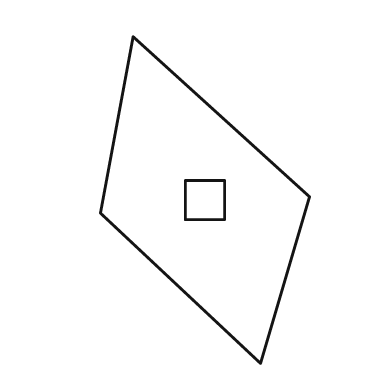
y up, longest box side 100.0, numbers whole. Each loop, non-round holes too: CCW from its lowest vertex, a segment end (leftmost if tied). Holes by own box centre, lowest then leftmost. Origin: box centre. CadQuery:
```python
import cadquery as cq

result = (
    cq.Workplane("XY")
    .moveTo(17.0, -50.0)
    .lineTo(32.0, 1.0)
    .lineTo(-22.0, 50.0)
    .lineTo(-32.0, -4.0)
    .close()
    .moveTo(-6.0, -6.0)
    .lineTo(6.0, -6.0)
    .lineTo(6.0, 6.0)
    .lineTo(-6.0, 6.0)
    .close()
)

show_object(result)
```